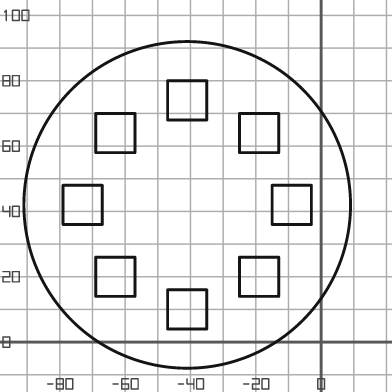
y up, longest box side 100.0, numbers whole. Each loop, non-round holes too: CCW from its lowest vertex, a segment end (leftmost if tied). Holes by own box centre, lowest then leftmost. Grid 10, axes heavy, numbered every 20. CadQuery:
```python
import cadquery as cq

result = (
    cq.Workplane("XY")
    .moveTo(-41.0, 42.0)
    .circle(50.0)
    .moveTo(-47.0, 4.0)
    .lineTo(-35.0, 4.0)
    .lineTo(-35.0, 16.0)
    .lineTo(-47.0, 16.0)
    .close()
    .moveTo(-69.0, 14.0)
    .lineTo(-57.0, 14.0)
    .lineTo(-57.0, 26.0)
    .lineTo(-69.0, 26.0)
    .close()
    .moveTo(-25.0, 14.0)
    .lineTo(-13.0, 14.0)
    .lineTo(-13.0, 26.0)
    .lineTo(-25.0, 26.0)
    .close()
    .moveTo(-79.0, 36.0)
    .lineTo(-67.0, 36.0)
    .lineTo(-67.0, 48.0)
    .lineTo(-79.0, 48.0)
    .close()
    .moveTo(-15.0, 36.0)
    .lineTo(-3.0, 36.0)
    .lineTo(-3.0, 48.0)
    .lineTo(-15.0, 48.0)
    .close()
    .moveTo(-69.0, 58.0)
    .lineTo(-57.0, 58.0)
    .lineTo(-57.0, 70.0)
    .lineTo(-69.0, 70.0)
    .close()
    .moveTo(-25.0, 58.0)
    .lineTo(-13.0, 58.0)
    .lineTo(-13.0, 70.0)
    .lineTo(-25.0, 70.0)
    .close()
    .moveTo(-47.0, 68.0)
    .lineTo(-35.0, 68.0)
    .lineTo(-35.0, 80.0)
    .lineTo(-47.0, 80.0)
    .close()
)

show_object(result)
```